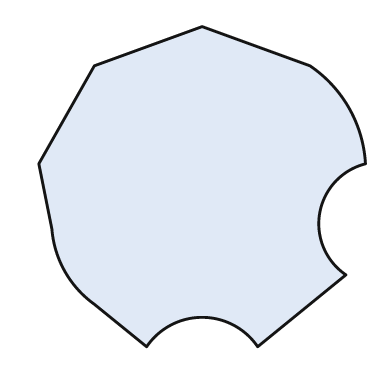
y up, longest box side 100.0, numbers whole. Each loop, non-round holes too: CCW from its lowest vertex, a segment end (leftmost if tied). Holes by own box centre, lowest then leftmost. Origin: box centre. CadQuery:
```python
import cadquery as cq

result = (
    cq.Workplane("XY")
    .moveTo(-17.0, -49.0)
    .threePointArc((0.0, -40.0), (17.0, -49.0))
    .lineTo(44.0, -27.0)
    .threePointArc((36.0, -8.0), (50.0, 7.0))
    .threePointArc((45.0, 24.0), (33.0, 37.0))
    .lineTo(0.0, 49.0)
    .lineTo(-33.0, 37.0)
    .lineTo(-50.0, 7.0)
    .lineTo(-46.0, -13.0)
    .threePointArc((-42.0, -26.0), (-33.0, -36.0))
    .close()
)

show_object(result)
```